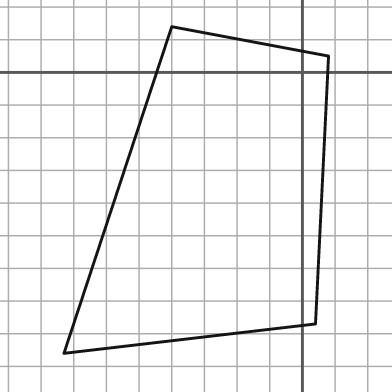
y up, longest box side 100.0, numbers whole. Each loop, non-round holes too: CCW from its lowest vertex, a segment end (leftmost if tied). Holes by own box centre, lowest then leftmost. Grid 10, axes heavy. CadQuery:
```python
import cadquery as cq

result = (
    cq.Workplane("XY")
    .moveTo(-73.0, -86.0)
    .lineTo(4.0, -77.0)
    .lineTo(8.0, 5.0)
    .lineTo(-40.0, 14.0)
    .close()
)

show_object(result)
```